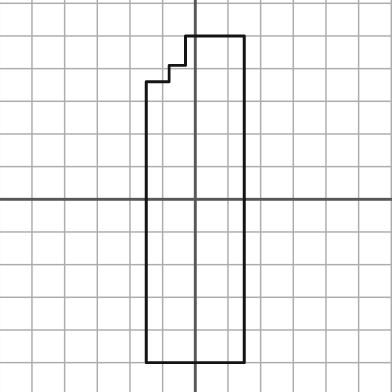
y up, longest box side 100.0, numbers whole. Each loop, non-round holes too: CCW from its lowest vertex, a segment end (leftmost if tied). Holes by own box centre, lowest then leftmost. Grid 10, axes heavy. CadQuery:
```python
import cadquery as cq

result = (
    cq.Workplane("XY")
    .moveTo(-15.0, -50.0)
    .lineTo(15.0, -50.0)
    .lineTo(15.0, 50.0)
    .lineTo(-3.0, 50.0)
    .lineTo(-3.0, 41.0)
    .lineTo(-8.0, 41.0)
    .lineTo(-8.0, 36.0)
    .lineTo(-15.0, 36.0)
    .close()
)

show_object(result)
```